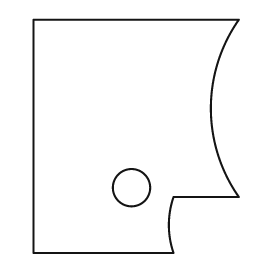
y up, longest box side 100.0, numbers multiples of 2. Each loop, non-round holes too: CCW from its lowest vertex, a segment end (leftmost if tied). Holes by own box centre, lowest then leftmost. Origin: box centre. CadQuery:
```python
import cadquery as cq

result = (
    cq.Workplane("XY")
    .moveTo(-44.0, -50.0)
    .lineTo(16.0, -50.0)
    .threePointArc((14.0, -38.0), (16.0, -26.0))
    .lineTo(44.0, -26.0)
    .threePointArc((32.0, 12.0), (44.0, 50.0))
    .lineTo(-44.0, 50.0)
    .close()
    .moveTo(-2.0, -22.0)
    .circle(8.0)
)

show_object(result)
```